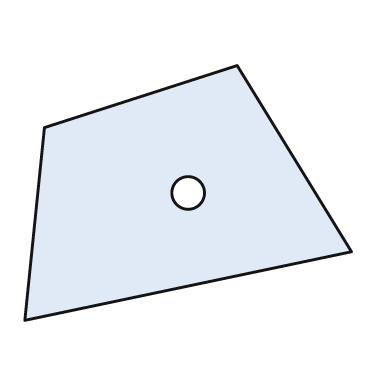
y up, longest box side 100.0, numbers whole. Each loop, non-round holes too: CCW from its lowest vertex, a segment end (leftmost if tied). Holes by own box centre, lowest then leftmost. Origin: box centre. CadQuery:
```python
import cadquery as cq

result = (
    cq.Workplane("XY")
    .moveTo(-50.0, -39.0)
    .lineTo(50.0, -18.0)
    .lineTo(15.0, 39.0)
    .lineTo(-44.0, 20.0)
    .close()
    .moveTo(0.0, 0.0)
    .circle(5.0)
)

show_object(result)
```